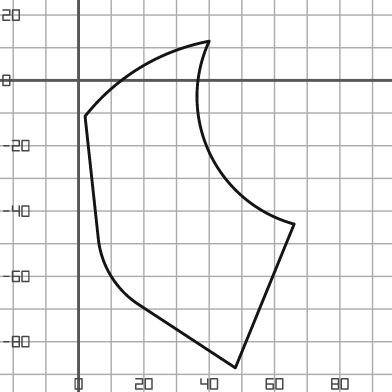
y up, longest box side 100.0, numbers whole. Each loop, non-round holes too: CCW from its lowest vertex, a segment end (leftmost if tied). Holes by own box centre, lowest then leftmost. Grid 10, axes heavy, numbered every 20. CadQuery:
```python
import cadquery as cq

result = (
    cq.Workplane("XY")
    .moveTo(48.0, -88.0)
    .lineTo(66.0, -44.0)
    .threePointArc((40.0, -22.0), (40.0, 12.0))
    .threePointArc((19.0, 4.0), (2.0, -11.0))
    .lineTo(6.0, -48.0)
    .threePointArc((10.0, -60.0), (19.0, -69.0))
    .close()
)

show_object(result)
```